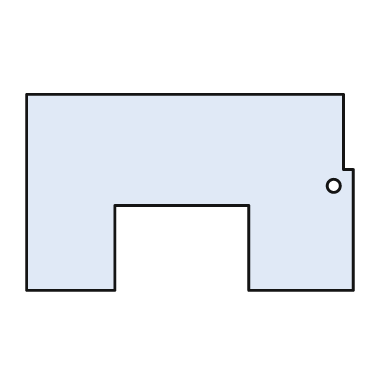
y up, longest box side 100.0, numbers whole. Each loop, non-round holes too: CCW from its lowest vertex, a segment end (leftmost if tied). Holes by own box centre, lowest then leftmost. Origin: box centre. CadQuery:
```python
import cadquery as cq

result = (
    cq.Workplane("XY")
    .moveTo(-50.0, -30.0)
    .lineTo(-23.0, -30.0)
    .lineTo(-23.0, -4.0)
    .lineTo(18.0, -4.0)
    .lineTo(18.0, -30.0)
    .lineTo(50.0, -30.0)
    .lineTo(50.0, 7.0)
    .lineTo(47.0, 7.0)
    .lineTo(47.0, 30.0)
    .lineTo(-50.0, 30.0)
    .close()
    .moveTo(44.0, 2.0)
    .circle(2.0)
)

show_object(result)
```